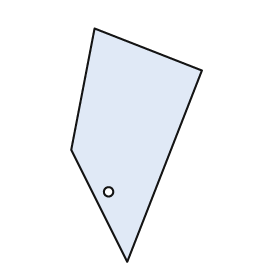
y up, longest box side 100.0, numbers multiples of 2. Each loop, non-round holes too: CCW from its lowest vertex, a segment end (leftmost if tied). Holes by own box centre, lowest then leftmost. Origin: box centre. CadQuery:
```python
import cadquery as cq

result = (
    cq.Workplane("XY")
    .moveTo(-4.0, -50.0)
    .lineTo(28.0, 32.0)
    .lineTo(-18.0, 50.0)
    .lineTo(-28.0, -2.0)
    .close()
    .moveTo(-12.0, -20.0)
    .circle(2.0)
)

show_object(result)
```